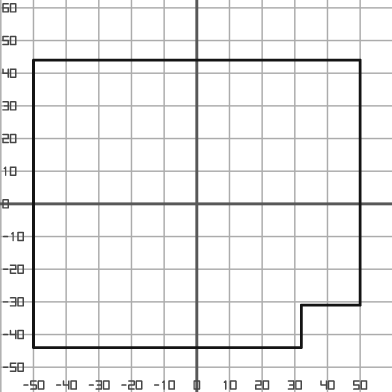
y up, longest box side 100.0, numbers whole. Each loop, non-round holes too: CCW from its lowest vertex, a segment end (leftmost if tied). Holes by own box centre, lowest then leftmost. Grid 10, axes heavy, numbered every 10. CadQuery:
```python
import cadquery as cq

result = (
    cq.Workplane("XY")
    .moveTo(-50.0, -44.0)
    .lineTo(32.0, -44.0)
    .lineTo(32.0, -31.0)
    .lineTo(50.0, -31.0)
    .lineTo(50.0, 44.0)
    .lineTo(-50.0, 44.0)
    .close()
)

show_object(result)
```